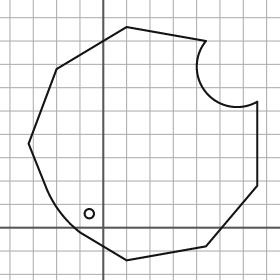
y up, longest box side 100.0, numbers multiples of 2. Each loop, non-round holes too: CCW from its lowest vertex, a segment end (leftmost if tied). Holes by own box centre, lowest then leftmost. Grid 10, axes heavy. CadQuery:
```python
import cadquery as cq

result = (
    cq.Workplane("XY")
    .moveTo(10.0, -14.0)
    .lineTo(44.0, -8.0)
    .lineTo(66.0, 18.0)
    .lineTo(66.0, 54.0)
    .threePointArc((44.0, 58.0), (44.0, 80.0))
    .lineTo(10.0, 86.0)
    .lineTo(-20.0, 68.0)
    .lineTo(-32.0, 36.0)
    .lineTo(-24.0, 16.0)
    .threePointArc((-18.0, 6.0), (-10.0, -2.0))
    .close()
    .moveTo(-6.0, 6.0)
    .circle(2.0)
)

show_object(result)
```